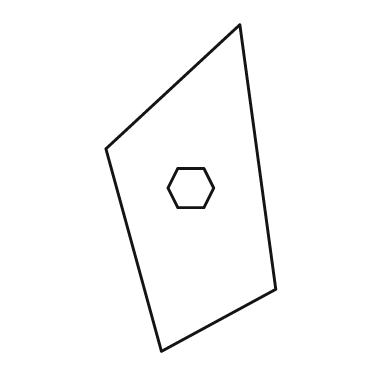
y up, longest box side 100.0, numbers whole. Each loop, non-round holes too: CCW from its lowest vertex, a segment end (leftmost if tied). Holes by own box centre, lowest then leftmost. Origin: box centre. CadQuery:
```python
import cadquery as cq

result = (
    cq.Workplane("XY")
    .moveTo(-9.0, -50.0)
    .lineTo(26.0, -31.0)
    .lineTo(15.0, 50.0)
    .lineTo(-26.0, 12.0)
    .close()
    .moveTo(-4.0, -6.0)
    .lineTo(4.0, -6.0)
    .lineTo(7.0, 0.0)
    .lineTo(4.0, 6.0)
    .lineTo(-4.0, 6.0)
    .lineTo(-7.0, 0.0)
    .close()
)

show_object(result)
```